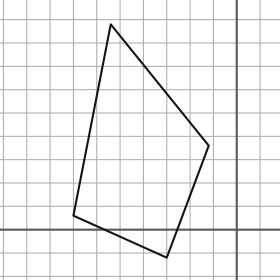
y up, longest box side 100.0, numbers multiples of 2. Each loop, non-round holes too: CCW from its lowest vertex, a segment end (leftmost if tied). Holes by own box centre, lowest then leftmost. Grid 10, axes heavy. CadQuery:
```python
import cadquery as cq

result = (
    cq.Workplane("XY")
    .moveTo(-30.0, -12.0)
    .lineTo(-12.0, 36.0)
    .lineTo(-54.0, 88.0)
    .lineTo(-70.0, 6.0)
    .close()
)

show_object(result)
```